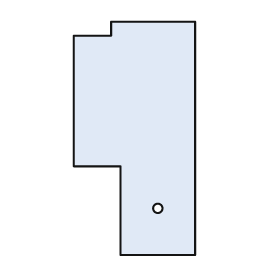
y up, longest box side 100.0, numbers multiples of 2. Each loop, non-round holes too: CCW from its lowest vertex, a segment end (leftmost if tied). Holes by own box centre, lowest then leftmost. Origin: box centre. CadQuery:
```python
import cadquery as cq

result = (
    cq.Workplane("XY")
    .moveTo(-6.0, -50.0)
    .lineTo(26.0, -50.0)
    .lineTo(26.0, 50.0)
    .lineTo(-10.0, 50.0)
    .lineTo(-10.0, 44.0)
    .lineTo(-26.0, 44.0)
    .lineTo(-26.0, -12.0)
    .lineTo(-6.0, -12.0)
    .close()
    .moveTo(10.0, -30.0)
    .circle(2.0)
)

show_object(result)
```